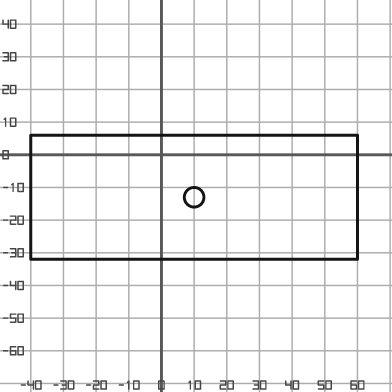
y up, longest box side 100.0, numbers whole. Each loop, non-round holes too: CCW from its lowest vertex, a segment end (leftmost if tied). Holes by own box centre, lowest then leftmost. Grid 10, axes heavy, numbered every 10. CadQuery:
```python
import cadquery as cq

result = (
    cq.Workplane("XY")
    .moveTo(-40.0, -32.0)
    .lineTo(60.0, -32.0)
    .lineTo(60.0, 6.0)
    .lineTo(-40.0, 6.0)
    .close()
    .moveTo(10.0, -13.0)
    .circle(3.0)
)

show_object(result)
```